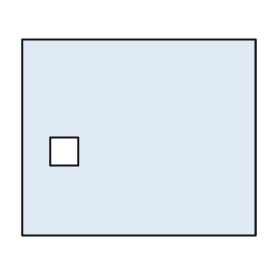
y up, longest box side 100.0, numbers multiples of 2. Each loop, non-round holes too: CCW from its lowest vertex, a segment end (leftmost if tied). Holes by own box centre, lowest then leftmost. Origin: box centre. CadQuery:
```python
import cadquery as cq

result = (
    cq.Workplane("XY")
    .moveTo(-50.0, -42.0)
    .lineTo(50.0, -42.0)
    .lineTo(50.0, 42.0)
    .lineTo(-50.0, 42.0)
    .close()
    .moveTo(-38.0, -12.0)
    .lineTo(-26.0, -12.0)
    .lineTo(-26.0, 0.0)
    .lineTo(-38.0, 0.0)
    .close()
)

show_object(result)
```